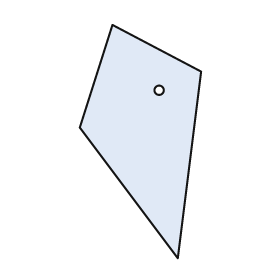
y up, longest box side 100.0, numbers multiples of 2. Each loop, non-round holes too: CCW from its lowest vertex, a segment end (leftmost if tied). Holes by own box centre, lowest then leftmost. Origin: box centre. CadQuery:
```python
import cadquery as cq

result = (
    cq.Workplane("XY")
    .moveTo(16.0, -50.0)
    .lineTo(26.0, 30.0)
    .lineTo(-12.0, 50.0)
    .lineTo(-26.0, 6.0)
    .close()
    .moveTo(8.0, 22.0)
    .circle(2.0)
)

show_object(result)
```